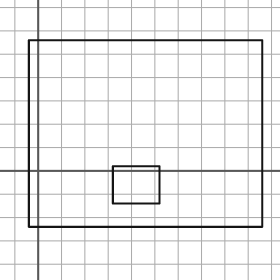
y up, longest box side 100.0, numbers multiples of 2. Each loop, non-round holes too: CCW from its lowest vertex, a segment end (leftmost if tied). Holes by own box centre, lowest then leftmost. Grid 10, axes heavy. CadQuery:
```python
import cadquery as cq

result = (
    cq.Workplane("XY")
    .moveTo(-4.0, -24.0)
    .lineTo(96.0, -24.0)
    .lineTo(96.0, 56.0)
    .lineTo(-4.0, 56.0)
    .close()
    .moveTo(32.0, -14.0)
    .lineTo(52.0, -14.0)
    .lineTo(52.0, 2.0)
    .lineTo(32.0, 2.0)
    .close()
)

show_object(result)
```